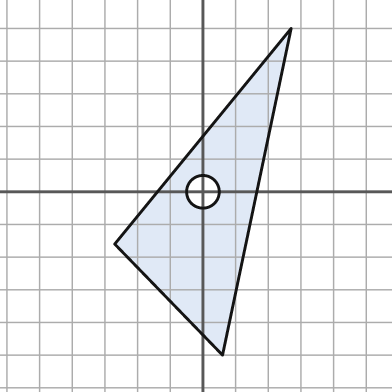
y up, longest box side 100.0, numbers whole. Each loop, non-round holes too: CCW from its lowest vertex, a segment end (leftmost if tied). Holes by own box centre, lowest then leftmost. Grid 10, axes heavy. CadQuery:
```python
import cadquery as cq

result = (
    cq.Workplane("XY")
    .moveTo(6.0, -50.0)
    .lineTo(27.0, 50.0)
    .lineTo(-27.0, -16.0)
    .close()
    .moveTo(0.0, 0.0)
    .circle(5.0)
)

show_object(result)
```